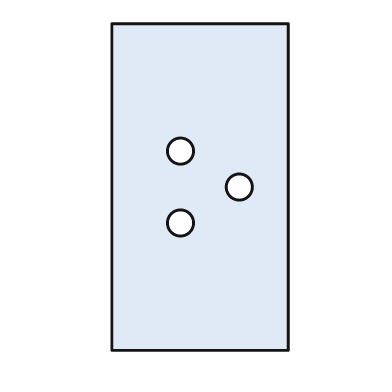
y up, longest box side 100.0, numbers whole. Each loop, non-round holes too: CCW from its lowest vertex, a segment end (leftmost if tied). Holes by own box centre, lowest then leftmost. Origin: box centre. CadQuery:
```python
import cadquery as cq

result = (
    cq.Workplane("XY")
    .moveTo(-27.0, -50.0)
    .lineTo(27.0, -50.0)
    .lineTo(27.0, 50.0)
    .lineTo(-27.0, 50.0)
    .close()
    .moveTo(-6.0, -11.0)
    .circle(4.0)
    .moveTo(12.0, 0.0)
    .circle(4.0)
    .moveTo(-6.0, 11.0)
    .circle(4.0)
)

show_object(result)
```